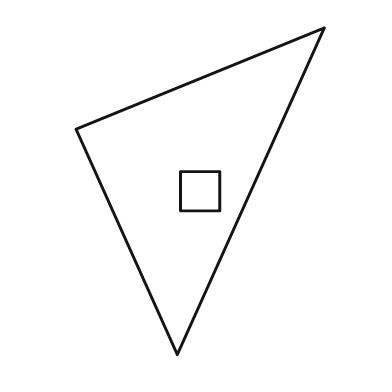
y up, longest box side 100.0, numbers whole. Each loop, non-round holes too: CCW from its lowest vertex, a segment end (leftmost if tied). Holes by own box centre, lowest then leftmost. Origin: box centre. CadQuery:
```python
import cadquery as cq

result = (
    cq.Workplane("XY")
    .moveTo(-7.0, -50.0)
    .lineTo(38.0, 50.0)
    .lineTo(-38.0, 19.0)
    .close()
    .moveTo(-6.0, -6.0)
    .lineTo(6.0, -6.0)
    .lineTo(6.0, 6.0)
    .lineTo(-6.0, 6.0)
    .close()
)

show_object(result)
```